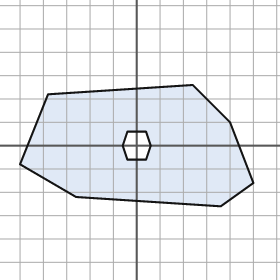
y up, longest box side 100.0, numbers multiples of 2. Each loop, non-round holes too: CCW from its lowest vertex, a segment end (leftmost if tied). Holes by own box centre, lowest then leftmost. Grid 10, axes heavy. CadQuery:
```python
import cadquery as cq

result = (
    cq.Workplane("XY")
    .moveTo(36.0, -26.0)
    .lineTo(50.0, -16.0)
    .lineTo(40.0, 10.0)
    .lineTo(24.0, 26.0)
    .lineTo(-38.0, 22.0)
    .lineTo(-50.0, -8.0)
    .lineTo(-26.0, -22.0)
    .close()
    .moveTo(-4.0, -6.0)
    .lineTo(4.0, -6.0)
    .lineTo(6.0, 0.0)
    .lineTo(4.0, 6.0)
    .lineTo(-4.0, 6.0)
    .lineTo(-6.0, 0.0)
    .close()
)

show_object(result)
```